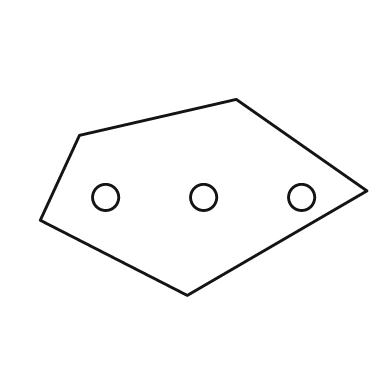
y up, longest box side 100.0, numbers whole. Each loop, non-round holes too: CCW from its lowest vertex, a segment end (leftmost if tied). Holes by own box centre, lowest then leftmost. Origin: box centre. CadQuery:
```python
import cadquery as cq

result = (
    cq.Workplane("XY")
    .moveTo(-5.0, -30.0)
    .lineTo(50.0, 2.0)
    .lineTo(10.0, 30.0)
    .lineTo(-38.0, 19.0)
    .lineTo(-50.0, -7.0)
    .close()
    .moveTo(-30.0, 0.0)
    .circle(4.0)
    .moveTo(0.0, 0.0)
    .circle(4.0)
    .moveTo(30.0, 0.0)
    .circle(4.0)
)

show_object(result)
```